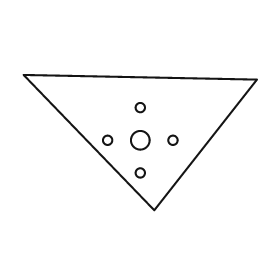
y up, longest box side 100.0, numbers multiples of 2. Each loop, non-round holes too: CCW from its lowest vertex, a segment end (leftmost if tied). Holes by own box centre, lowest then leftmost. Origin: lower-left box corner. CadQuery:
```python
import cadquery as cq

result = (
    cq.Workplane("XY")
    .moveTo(56.0, 0.0)
    .lineTo(100.0, 56.0)
    .lineTo(0.0, 58.0)
    .close()
    .moveTo(50.0, 16.0)
    .circle(2.0)
    .moveTo(36.0, 30.0)
    .circle(2.0)
    .moveTo(50.0, 30.0)
    .circle(4.0)
    .moveTo(64.0, 30.0)
    .circle(2.0)
    .moveTo(50.0, 44.0)
    .circle(2.0)
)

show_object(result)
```